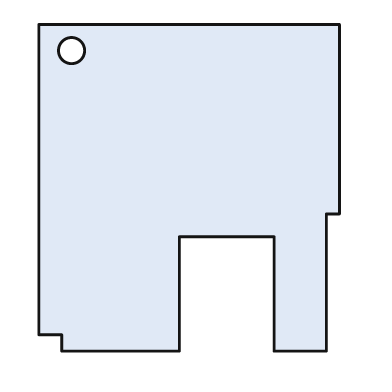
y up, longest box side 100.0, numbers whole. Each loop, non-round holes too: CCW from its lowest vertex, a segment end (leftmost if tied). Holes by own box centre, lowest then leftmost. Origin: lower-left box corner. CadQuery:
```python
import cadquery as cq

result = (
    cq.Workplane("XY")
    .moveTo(7.0, 0.0)
    .lineTo(43.0, 0.0)
    .lineTo(43.0, 35.0)
    .lineTo(72.0, 35.0)
    .lineTo(72.0, 0.0)
    .lineTo(88.0, 0.0)
    .lineTo(88.0, 42.0)
    .lineTo(92.0, 42.0)
    .lineTo(92.0, 100.0)
    .lineTo(0.0, 100.0)
    .lineTo(0.0, 5.0)
    .lineTo(7.0, 5.0)
    .close()
    .moveTo(10.0, 92.0)
    .circle(4.0)
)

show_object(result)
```